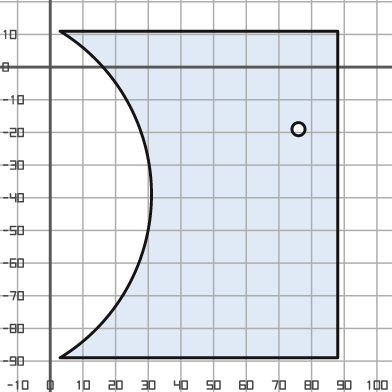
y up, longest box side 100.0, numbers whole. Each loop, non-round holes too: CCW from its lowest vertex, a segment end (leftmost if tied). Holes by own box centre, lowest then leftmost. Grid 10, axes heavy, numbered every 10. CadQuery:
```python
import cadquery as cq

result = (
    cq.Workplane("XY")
    .moveTo(3.0, -89.0)
    .lineTo(88.0, -89.0)
    .lineTo(88.0, 11.0)
    .lineTo(3.0, 11.0)
    .threePointArc((31.0, -39.0), (3.0, -89.0))
    .close()
    .moveTo(76.0, -19.0)
    .circle(2.0)
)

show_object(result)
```